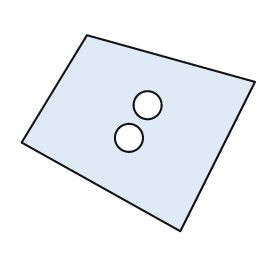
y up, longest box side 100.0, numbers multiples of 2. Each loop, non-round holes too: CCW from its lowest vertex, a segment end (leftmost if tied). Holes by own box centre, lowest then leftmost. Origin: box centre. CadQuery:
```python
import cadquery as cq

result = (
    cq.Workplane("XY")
    .moveTo(18.0, -42.0)
    .lineTo(50.0, 22.0)
    .lineTo(-22.0, 42.0)
    .lineTo(-50.0, -4.0)
    .close()
    .moveTo(-4.0, -2.0)
    .circle(6.0)
    .moveTo(4.0, 12.0)
    .circle(6.0)
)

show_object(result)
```